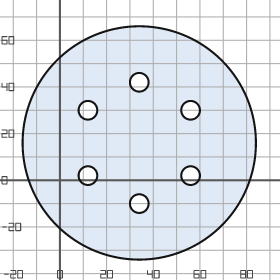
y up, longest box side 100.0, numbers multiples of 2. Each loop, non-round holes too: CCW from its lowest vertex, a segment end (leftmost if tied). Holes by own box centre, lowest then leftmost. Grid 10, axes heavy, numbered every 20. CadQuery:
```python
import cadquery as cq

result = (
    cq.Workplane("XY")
    .moveTo(34.0, 16.0)
    .circle(50.0)
    .moveTo(34.0, -10.0)
    .circle(4.0)
    .moveTo(12.0, 2.0)
    .circle(4.0)
    .moveTo(56.0, 2.0)
    .circle(4.0)
    .moveTo(12.0, 30.0)
    .circle(4.0)
    .moveTo(56.0, 30.0)
    .circle(4.0)
    .moveTo(34.0, 42.0)
    .circle(4.0)
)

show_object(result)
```